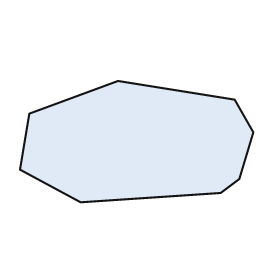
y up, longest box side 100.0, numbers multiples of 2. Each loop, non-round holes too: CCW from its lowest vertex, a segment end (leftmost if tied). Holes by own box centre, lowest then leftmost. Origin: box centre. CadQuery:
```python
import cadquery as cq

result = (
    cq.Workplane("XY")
    .moveTo(-24.0, -26.0)
    .lineTo(36.0, -22.0)
    .lineTo(44.0, -16.0)
    .lineTo(50.0, 4.0)
    .lineTo(42.0, 18.0)
    .lineTo(-8.0, 26.0)
    .lineTo(-46.0, 12.0)
    .lineTo(-50.0, -12.0)
    .close()
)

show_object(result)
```